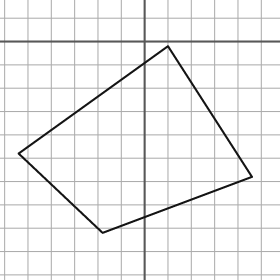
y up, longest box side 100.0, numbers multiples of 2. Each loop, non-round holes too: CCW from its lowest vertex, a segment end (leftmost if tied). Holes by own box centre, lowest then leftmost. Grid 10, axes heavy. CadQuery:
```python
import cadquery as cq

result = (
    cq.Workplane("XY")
    .moveTo(-18.0, -82.0)
    .lineTo(46.0, -58.0)
    .lineTo(10.0, -2.0)
    .lineTo(-54.0, -48.0)
    .close()
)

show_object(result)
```